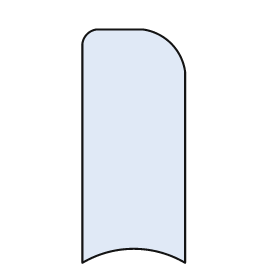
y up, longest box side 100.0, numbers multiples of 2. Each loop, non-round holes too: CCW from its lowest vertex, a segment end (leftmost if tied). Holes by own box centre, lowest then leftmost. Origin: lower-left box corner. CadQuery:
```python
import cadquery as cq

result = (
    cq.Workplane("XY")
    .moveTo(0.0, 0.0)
    .threePointArc((22.0, 6.0), (44.0, 0.0))
    .lineTo(44.0, 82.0)
    .threePointArc((38.0, 94.0), (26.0, 100.0))
    .lineTo(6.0, 100.0)
    .threePointArc((2.0, 98.0), (0.0, 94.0))
    .close()
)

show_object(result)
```